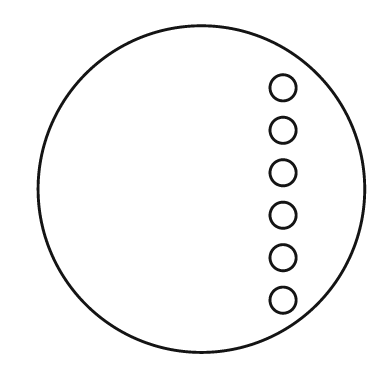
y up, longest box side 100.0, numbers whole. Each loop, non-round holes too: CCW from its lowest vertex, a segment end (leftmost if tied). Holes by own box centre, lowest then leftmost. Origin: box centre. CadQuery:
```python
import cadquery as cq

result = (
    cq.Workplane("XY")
    .moveTo(0.0, 0.0)
    .circle(50.0)
    .moveTo(25.0, -34.0)
    .circle(4.0)
    .moveTo(25.0, -21.0)
    .circle(4.0)
    .moveTo(25.0, -8.0)
    .circle(4.0)
    .moveTo(25.0, 5.0)
    .circle(4.0)
    .moveTo(25.0, 18.0)
    .circle(4.0)
    .moveTo(25.0, 31.0)
    .circle(4.0)
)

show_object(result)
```